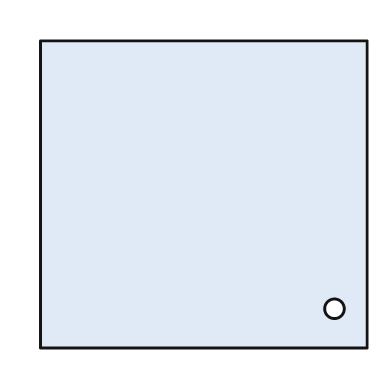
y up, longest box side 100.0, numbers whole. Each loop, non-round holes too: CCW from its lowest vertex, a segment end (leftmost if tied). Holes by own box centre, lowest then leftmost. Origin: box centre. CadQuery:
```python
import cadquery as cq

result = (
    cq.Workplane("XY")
    .moveTo(-50.0, -47.0)
    .lineTo(50.0, -47.0)
    .lineTo(50.0, 47.0)
    .lineTo(-50.0, 47.0)
    .close()
    .moveTo(40.0, -35.0)
    .circle(3.0)
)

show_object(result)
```